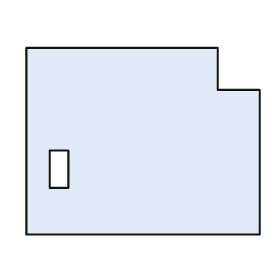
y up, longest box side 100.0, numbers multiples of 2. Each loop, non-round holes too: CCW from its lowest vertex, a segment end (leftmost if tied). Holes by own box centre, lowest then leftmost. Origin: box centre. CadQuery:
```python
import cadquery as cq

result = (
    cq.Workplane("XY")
    .moveTo(-50.0, -40.0)
    .lineTo(50.0, -40.0)
    .lineTo(50.0, 22.0)
    .lineTo(32.0, 22.0)
    .lineTo(32.0, 40.0)
    .lineTo(-50.0, 40.0)
    .close()
    .moveTo(-40.0, -20.0)
    .lineTo(-32.0, -20.0)
    .lineTo(-32.0, -4.0)
    .lineTo(-40.0, -4.0)
    .close()
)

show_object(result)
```